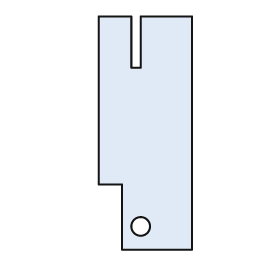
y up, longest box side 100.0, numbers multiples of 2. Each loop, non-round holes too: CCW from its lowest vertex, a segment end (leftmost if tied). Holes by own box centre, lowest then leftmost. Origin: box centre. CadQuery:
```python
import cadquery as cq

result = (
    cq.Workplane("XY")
    .moveTo(-10.0, -50.0)
    .lineTo(20.0, -50.0)
    .lineTo(20.0, 50.0)
    .lineTo(-2.0, 50.0)
    .lineTo(-2.0, 28.0)
    .lineTo(-6.0, 28.0)
    .lineTo(-6.0, 50.0)
    .lineTo(-20.0, 50.0)
    .lineTo(-20.0, -22.0)
    .lineTo(-10.0, -22.0)
    .close()
    .moveTo(-2.0, -40.0)
    .circle(4.0)
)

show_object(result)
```